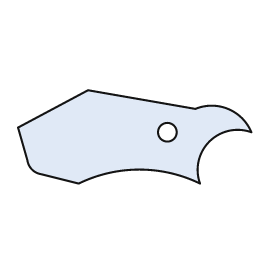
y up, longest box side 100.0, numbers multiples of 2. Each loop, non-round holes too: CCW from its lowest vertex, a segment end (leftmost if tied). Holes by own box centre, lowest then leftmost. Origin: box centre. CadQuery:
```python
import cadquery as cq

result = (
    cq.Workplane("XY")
    .moveTo(-24.0, -20.0)
    .threePointArc((2.0, -14.0), (28.0, -20.0))
    .threePointArc((32.0, -2.0), (50.0, 2.0))
    .threePointArc((40.0, 12.0), (26.0, 12.0))
    .lineTo(-20.0, 20.0)
    .lineTo(-50.0, 4.0)
    .lineTo(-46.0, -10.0)
    .threePointArc((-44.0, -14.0), (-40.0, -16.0))
    .close()
    .moveTo(14.0, 2.0)
    .circle(4.0)
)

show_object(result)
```